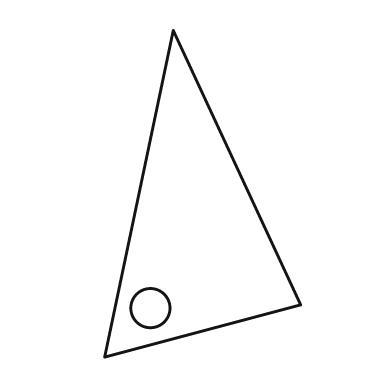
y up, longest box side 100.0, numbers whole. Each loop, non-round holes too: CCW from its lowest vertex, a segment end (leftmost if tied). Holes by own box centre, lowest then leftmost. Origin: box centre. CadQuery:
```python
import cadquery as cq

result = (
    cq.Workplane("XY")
    .moveTo(-30.0, -50.0)
    .lineTo(30.0, -34.0)
    .lineTo(-9.0, 50.0)
    .close()
    .moveTo(-16.0, -35.0)
    .circle(6.0)
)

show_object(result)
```